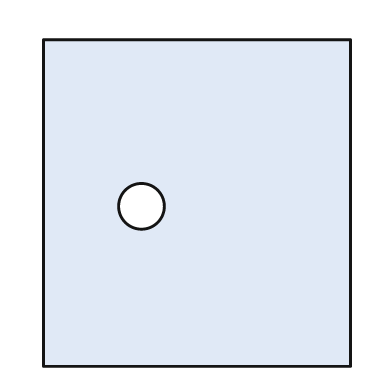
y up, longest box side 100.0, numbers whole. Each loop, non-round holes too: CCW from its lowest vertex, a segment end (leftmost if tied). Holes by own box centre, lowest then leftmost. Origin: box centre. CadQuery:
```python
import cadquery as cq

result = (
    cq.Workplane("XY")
    .moveTo(-47.0, -50.0)
    .lineTo(47.0, -50.0)
    .lineTo(47.0, 50.0)
    .lineTo(-47.0, 50.0)
    .close()
    .moveTo(-17.0, -1.0)
    .circle(7.0)
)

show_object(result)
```